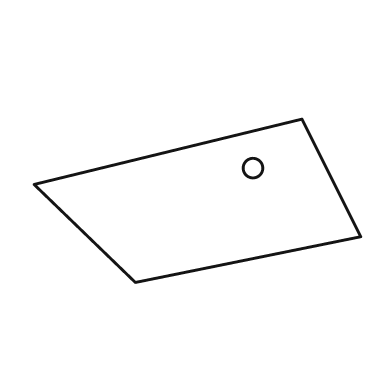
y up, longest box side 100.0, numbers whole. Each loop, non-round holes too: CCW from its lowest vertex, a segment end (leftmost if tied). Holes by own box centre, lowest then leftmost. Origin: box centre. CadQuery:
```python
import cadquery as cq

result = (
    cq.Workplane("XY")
    .moveTo(-19.0, -25.0)
    .lineTo(50.0, -11.0)
    .lineTo(32.0, 25.0)
    .lineTo(-50.0, 5.0)
    .close()
    .moveTo(17.0, 10.0)
    .circle(3.0)
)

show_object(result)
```